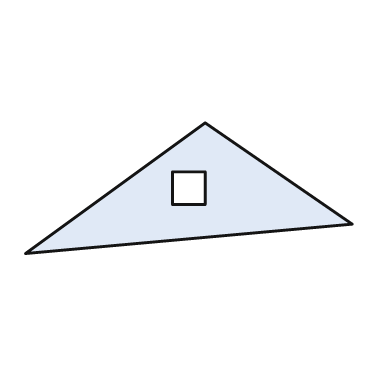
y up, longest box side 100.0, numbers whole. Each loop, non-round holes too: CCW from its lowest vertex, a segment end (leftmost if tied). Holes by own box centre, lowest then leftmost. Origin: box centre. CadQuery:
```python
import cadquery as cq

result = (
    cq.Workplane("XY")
    .moveTo(-50.0, -20.0)
    .lineTo(50.0, -11.0)
    .lineTo(5.0, 20.0)
    .close()
    .moveTo(-5.0, -5.0)
    .lineTo(5.0, -5.0)
    .lineTo(5.0, 5.0)
    .lineTo(-5.0, 5.0)
    .close()
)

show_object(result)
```